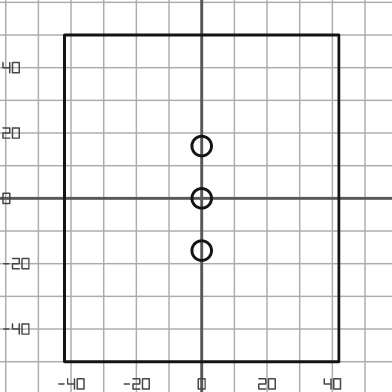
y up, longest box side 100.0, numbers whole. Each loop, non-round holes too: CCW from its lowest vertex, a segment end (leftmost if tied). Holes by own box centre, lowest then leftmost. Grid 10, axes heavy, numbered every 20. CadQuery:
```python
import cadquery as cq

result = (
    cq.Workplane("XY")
    .moveTo(-42.0, -50.0)
    .lineTo(42.0, -50.0)
    .lineTo(42.0, 50.0)
    .lineTo(-42.0, 50.0)
    .close()
    .moveTo(0.0, -16.0)
    .circle(3.0)
    .moveTo(0.0, 0.0)
    .circle(3.0)
    .moveTo(0.0, 16.0)
    .circle(3.0)
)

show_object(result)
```